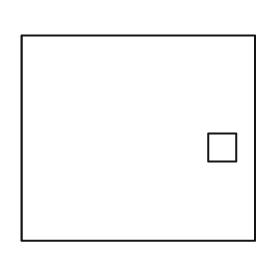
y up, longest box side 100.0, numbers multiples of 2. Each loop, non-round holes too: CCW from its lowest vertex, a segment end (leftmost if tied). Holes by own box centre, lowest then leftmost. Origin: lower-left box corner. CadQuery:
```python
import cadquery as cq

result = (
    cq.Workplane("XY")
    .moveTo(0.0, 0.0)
    .lineTo(100.0, 0.0)
    .lineTo(100.0, 88.0)
    .lineTo(0.0, 88.0)
    .close()
    .moveTo(80.0, 34.0)
    .lineTo(92.0, 34.0)
    .lineTo(92.0, 46.0)
    .lineTo(80.0, 46.0)
    .close()
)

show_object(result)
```